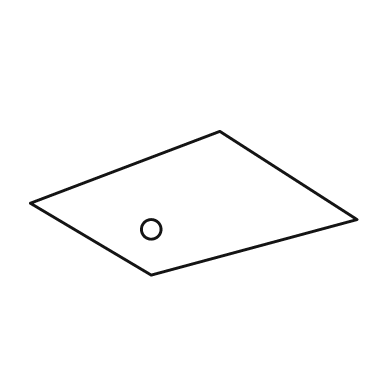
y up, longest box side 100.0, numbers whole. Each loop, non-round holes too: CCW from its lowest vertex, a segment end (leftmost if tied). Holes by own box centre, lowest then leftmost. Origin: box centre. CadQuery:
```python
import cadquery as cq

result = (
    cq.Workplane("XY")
    .moveTo(-13.0, -22.0)
    .lineTo(50.0, -5.0)
    .lineTo(8.0, 22.0)
    .lineTo(-50.0, 0.0)
    .close()
    .moveTo(-13.0, -8.0)
    .circle(3.0)
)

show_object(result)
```